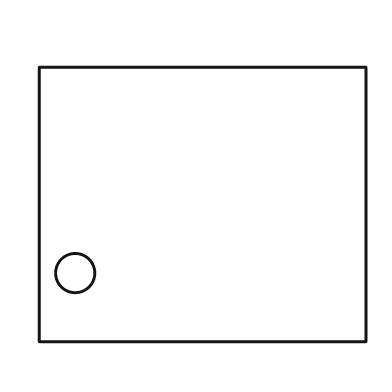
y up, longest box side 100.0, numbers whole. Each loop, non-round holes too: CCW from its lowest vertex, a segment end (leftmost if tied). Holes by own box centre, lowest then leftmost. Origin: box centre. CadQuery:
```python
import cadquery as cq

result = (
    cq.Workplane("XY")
    .moveTo(-50.0, -42.0)
    .lineTo(50.0, -42.0)
    .lineTo(50.0, 42.0)
    .lineTo(-50.0, 42.0)
    .close()
    .moveTo(-39.0, -21.0)
    .circle(6.0)
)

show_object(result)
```